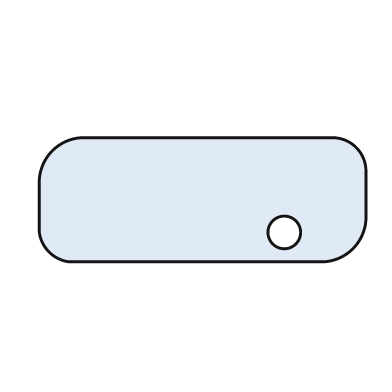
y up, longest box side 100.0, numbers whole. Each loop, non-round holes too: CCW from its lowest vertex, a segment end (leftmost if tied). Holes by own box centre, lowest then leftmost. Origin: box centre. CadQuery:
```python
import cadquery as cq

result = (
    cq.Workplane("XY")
    .moveTo(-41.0, -19.0)
    .lineTo(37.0, -19.0)
    .threePointArc((46.0, -15.0), (50.0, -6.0))
    .lineTo(50.0, 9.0)
    .threePointArc((47.0, 16.0), (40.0, 19.0))
    .lineTo(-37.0, 19.0)
    .threePointArc((-46.0, 15.0), (-50.0, 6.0))
    .lineTo(-50.0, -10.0)
    .threePointArc((-47.0, -16.0), (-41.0, -19.0))
    .close()
    .moveTo(25.0, -10.0)
    .circle(5.0)
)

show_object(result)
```